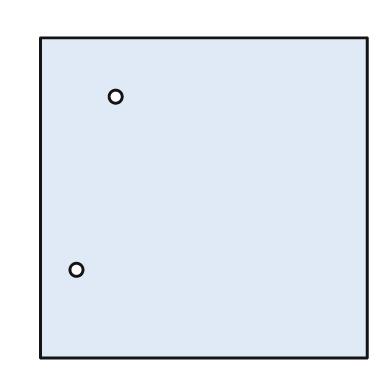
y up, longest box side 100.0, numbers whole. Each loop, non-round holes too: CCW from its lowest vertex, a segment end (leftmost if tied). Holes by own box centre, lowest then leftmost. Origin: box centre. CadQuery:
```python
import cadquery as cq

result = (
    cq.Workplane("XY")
    .moveTo(-50.0, -49.0)
    .lineTo(50.0, -49.0)
    .lineTo(50.0, 49.0)
    .lineTo(-50.0, 49.0)
    .close()
    .moveTo(-39.0, -22.0)
    .circle(2.0)
    .moveTo(-27.0, 31.0)
    .circle(2.0)
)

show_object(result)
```